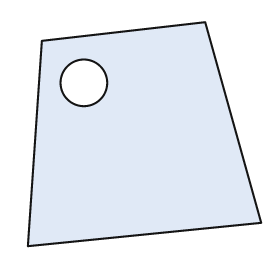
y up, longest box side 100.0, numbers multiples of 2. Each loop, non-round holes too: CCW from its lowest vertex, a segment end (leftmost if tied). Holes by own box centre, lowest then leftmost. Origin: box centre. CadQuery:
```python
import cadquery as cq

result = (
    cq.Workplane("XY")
    .moveTo(-50.0, -48.0)
    .lineTo(50.0, -38.0)
    .lineTo(26.0, 48.0)
    .lineTo(-44.0, 40.0)
    .close()
    .moveTo(-26.0, 22.0)
    .circle(10.0)
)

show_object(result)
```